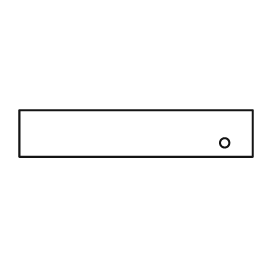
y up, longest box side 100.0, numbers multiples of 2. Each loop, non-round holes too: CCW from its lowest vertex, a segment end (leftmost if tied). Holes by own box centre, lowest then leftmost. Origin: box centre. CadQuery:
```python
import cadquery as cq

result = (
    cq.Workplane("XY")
    .moveTo(-50.0, -10.0)
    .lineTo(50.0, -10.0)
    .lineTo(50.0, 10.0)
    .lineTo(-50.0, 10.0)
    .close()
    .moveTo(38.0, -4.0)
    .circle(2.0)
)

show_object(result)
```